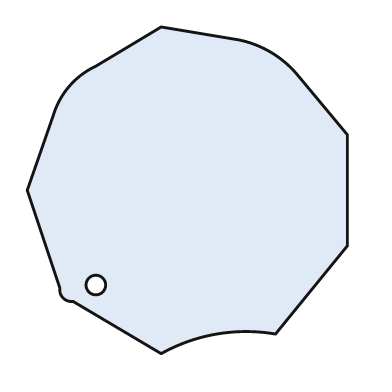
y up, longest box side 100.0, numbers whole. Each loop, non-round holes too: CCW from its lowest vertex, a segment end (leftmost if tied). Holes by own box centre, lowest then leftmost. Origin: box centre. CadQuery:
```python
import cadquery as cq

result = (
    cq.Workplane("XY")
    .moveTo(-8.0, -50.0)
    .threePointArc((9.0, -44.0), (27.0, -44.0))
    .lineTo(49.0, -17.0)
    .lineTo(49.0, 17.0)
    .lineTo(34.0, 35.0)
    .threePointArc((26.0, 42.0), (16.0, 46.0))
    .lineTo(-8.0, 50.0)
    .lineTo(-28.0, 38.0)
    .threePointArc((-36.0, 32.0), (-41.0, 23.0))
    .lineTo(-49.0, 0.0)
    .lineTo(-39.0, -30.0)
    .threePointArc((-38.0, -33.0), (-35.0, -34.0))
    .close()
    .moveTo(-28.0, -29.0)
    .circle(3.0)
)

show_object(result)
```